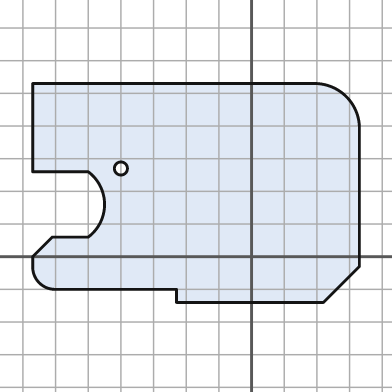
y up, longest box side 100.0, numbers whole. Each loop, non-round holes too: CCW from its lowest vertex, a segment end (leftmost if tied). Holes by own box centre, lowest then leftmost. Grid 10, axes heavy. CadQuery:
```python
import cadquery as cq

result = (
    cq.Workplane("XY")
    .moveTo(-23.0, -14.0)
    .lineTo(22.0, -14.0)
    .lineTo(33.0, -3.0)
    .lineTo(33.0, 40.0)
    .threePointArc((29.0, 49.0), (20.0, 53.0))
    .lineTo(-67.0, 53.0)
    .lineTo(-67.0, 26.0)
    .lineTo(-50.0, 26.0)
    .threePointArc((-45.0, 16.0), (-50.0, 6.0))
    .lineTo(-61.0, 6.0)
    .lineTo(-67.0, 0.0)
    .lineTo(-67.0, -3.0)
    .threePointArc((-65.0, -8.0), (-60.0, -10.0))
    .lineTo(-23.0, -10.0)
    .close()
    .moveTo(-40.0, 27.0)
    .circle(2.0)
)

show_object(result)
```